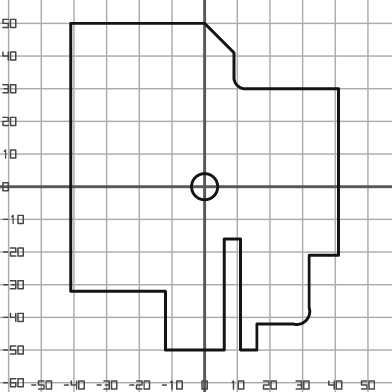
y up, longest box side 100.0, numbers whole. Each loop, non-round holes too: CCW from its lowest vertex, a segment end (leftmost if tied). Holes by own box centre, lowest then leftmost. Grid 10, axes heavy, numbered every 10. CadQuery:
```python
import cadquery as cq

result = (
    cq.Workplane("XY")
    .moveTo(-12.0, -50.0)
    .lineTo(6.0, -50.0)
    .lineTo(6.0, -16.0)
    .lineTo(11.0, -16.0)
    .lineTo(11.0, -50.0)
    .lineTo(16.0, -50.0)
    .lineTo(16.0, -42.0)
    .lineTo(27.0, -42.0)
    .threePointArc((31.0, -41.0), (32.0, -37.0))
    .lineTo(32.0, -21.0)
    .lineTo(41.0, -21.0)
    .lineTo(41.0, 30.0)
    .lineTo(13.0, 30.0)
    .threePointArc((10.0, 31.0), (9.0, 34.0))
    .lineTo(9.0, 41.0)
    .lineTo(0.0, 50.0)
    .lineTo(-41.0, 50.0)
    .lineTo(-41.0, -32.0)
    .lineTo(-12.0, -32.0)
    .close()
    .moveTo(0.0, 0.0)
    .circle(4.0)
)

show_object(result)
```